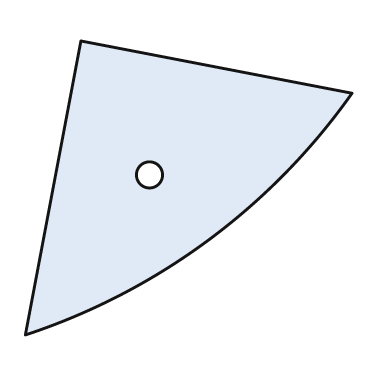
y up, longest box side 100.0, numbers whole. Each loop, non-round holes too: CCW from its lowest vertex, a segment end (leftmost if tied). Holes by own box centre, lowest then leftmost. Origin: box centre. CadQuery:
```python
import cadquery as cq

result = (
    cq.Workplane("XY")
    .moveTo(-50.0, -45.0)
    .threePointArc((6.0, -16.0), (50.0, 29.0))
    .lineTo(-33.0, 45.0)
    .close()
    .moveTo(-12.0, 4.0)
    .circle(4.0)
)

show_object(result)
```